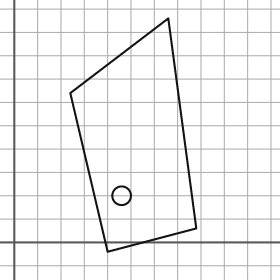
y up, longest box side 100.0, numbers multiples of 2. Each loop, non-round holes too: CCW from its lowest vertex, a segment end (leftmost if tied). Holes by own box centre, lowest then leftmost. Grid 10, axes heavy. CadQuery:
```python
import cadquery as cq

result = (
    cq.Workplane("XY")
    .moveTo(40.0, -4.0)
    .lineTo(78.0, 6.0)
    .lineTo(66.0, 96.0)
    .lineTo(24.0, 64.0)
    .close()
    .moveTo(46.0, 20.0)
    .circle(4.0)
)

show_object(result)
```